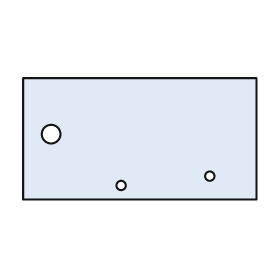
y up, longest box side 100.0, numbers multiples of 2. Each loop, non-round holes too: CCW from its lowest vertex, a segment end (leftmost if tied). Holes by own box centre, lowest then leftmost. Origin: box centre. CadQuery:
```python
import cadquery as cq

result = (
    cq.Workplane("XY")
    .moveTo(-50.0, -26.0)
    .lineTo(50.0, -26.0)
    .lineTo(50.0, 26.0)
    .lineTo(-50.0, 26.0)
    .close()
    .moveTo(-8.0, -20.0)
    .circle(2.0)
    .moveTo(30.0, -16.0)
    .circle(2.0)
    .moveTo(-38.0, 2.0)
    .circle(4.0)
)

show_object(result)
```